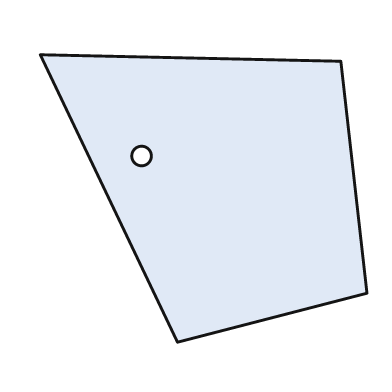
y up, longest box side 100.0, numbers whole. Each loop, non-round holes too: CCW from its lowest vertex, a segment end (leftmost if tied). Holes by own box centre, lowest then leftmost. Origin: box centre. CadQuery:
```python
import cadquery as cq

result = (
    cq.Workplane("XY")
    .moveTo(-8.0, -44.0)
    .lineTo(50.0, -29.0)
    .lineTo(42.0, 42.0)
    .lineTo(-50.0, 44.0)
    .close()
    .moveTo(-19.0, 13.0)
    .circle(3.0)
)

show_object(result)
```